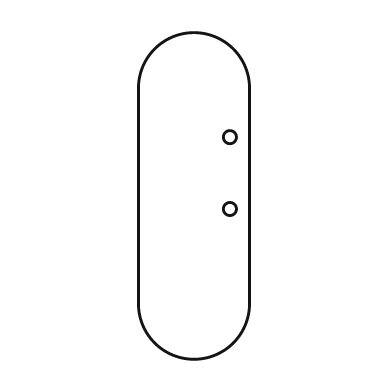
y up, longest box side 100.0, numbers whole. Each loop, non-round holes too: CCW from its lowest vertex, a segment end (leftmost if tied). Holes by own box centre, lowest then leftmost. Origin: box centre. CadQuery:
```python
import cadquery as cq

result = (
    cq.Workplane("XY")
    .moveTo(-17.0, -33.0)
    .threePointArc((0.0, -50.0), (17.0, -33.0))
    .lineTo(17.0, 33.0)
    .threePointArc((0.0, 50.0), (-17.0, 33.0))
    .close()
    .moveTo(11.0, -4.0)
    .circle(2.0)
    .moveTo(11.0, 18.0)
    .circle(2.0)
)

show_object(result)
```